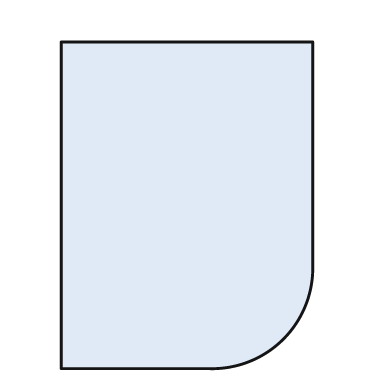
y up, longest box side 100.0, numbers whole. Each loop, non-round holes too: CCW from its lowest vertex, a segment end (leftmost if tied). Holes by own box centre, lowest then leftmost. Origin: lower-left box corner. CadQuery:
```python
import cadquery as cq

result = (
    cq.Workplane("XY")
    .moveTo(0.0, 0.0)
    .lineTo(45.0, 0.0)
    .threePointArc((68.0, 9.0), (77.0, 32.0))
    .lineTo(77.0, 100.0)
    .lineTo(0.0, 100.0)
    .close()
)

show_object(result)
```